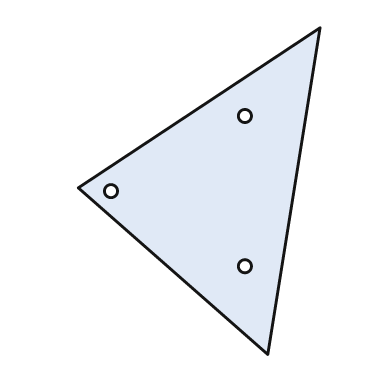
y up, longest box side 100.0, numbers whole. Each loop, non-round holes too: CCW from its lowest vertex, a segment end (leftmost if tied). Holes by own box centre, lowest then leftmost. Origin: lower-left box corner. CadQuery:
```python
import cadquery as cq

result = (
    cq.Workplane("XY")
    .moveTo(58.0, 0.0)
    .lineTo(74.0, 100.0)
    .lineTo(0.0, 51.0)
    .close()
    .moveTo(51.0, 27.0)
    .circle(2.0)
    .moveTo(10.0, 50.0)
    .circle(2.0)
    .moveTo(51.0, 73.0)
    .circle(2.0)
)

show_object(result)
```